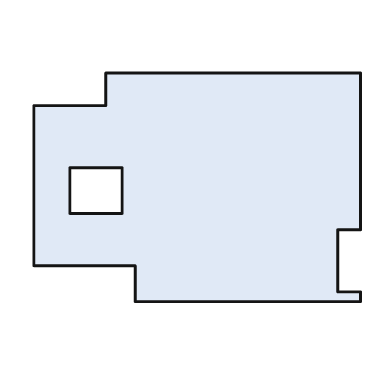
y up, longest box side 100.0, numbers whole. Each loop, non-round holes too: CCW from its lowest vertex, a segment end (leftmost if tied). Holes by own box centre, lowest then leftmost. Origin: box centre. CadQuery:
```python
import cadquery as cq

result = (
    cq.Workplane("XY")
    .moveTo(-19.0, -35.0)
    .lineTo(50.0, -35.0)
    .lineTo(50.0, -32.0)
    .lineTo(43.0, -32.0)
    .lineTo(43.0, -13.0)
    .lineTo(50.0, -13.0)
    .lineTo(50.0, 35.0)
    .lineTo(-28.0, 35.0)
    .lineTo(-28.0, 25.0)
    .lineTo(-50.0, 25.0)
    .lineTo(-50.0, -24.0)
    .lineTo(-19.0, -24.0)
    .close()
    .moveTo(-39.0, -8.0)
    .lineTo(-23.0, -8.0)
    .lineTo(-23.0, 6.0)
    .lineTo(-39.0, 6.0)
    .close()
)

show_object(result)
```